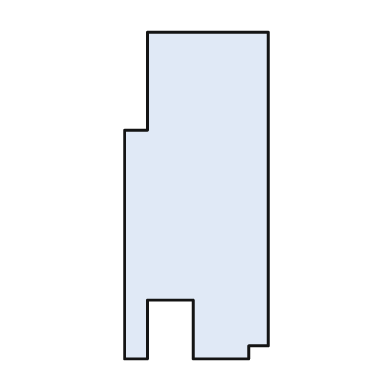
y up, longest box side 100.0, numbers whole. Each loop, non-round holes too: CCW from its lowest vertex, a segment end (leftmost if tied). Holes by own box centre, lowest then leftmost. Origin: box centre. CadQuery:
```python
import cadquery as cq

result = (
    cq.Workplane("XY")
    .moveTo(-22.0, -50.0)
    .lineTo(-15.0, -50.0)
    .lineTo(-15.0, -32.0)
    .lineTo(-1.0, -32.0)
    .lineTo(-1.0, -50.0)
    .lineTo(16.0, -50.0)
    .lineTo(16.0, -46.0)
    .lineTo(22.0, -46.0)
    .lineTo(22.0, 50.0)
    .lineTo(-15.0, 50.0)
    .lineTo(-15.0, 20.0)
    .lineTo(-22.0, 20.0)
    .close()
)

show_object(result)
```